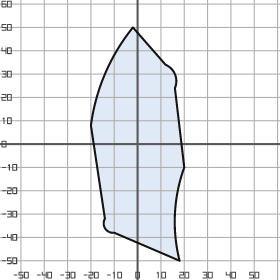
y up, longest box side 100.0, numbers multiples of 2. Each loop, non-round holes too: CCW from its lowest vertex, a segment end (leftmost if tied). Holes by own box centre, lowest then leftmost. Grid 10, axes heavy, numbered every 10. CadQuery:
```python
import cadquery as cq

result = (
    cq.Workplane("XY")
    .moveTo(18.0, -50.0)
    .threePointArc((16.0, -30.0), (20.0, -10.0))
    .lineTo(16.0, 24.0)
    .threePointArc((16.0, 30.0), (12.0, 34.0))
    .lineTo(-2.0, 50.0)
    .threePointArc((-14.0, 30.0), (-20.0, 8.0))
    .lineTo(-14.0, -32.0)
    .threePointArc((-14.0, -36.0), (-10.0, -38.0))
    .close()
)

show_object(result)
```